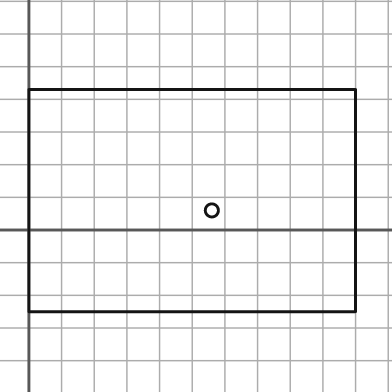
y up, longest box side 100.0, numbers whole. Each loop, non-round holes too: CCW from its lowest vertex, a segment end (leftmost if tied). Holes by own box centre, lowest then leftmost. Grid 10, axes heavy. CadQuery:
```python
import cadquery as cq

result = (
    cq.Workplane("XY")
    .moveTo(0.0, -25.0)
    .lineTo(100.0, -25.0)
    .lineTo(100.0, 43.0)
    .lineTo(0.0, 43.0)
    .close()
    .moveTo(56.0, 6.0)
    .circle(2.0)
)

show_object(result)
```